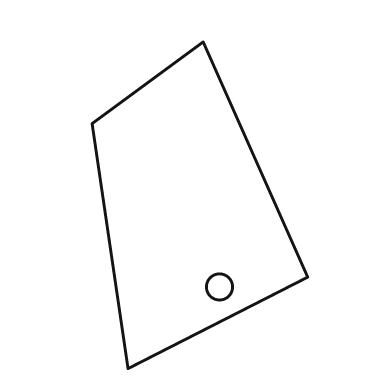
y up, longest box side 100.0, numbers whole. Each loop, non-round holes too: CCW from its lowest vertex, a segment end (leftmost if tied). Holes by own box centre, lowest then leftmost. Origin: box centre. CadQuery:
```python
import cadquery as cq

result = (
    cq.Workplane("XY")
    .moveTo(-22.0, -50.0)
    .lineTo(33.0, -22.0)
    .lineTo(1.0, 50.0)
    .lineTo(-33.0, 25.0)
    .close()
    .moveTo(6.0, -25.0)
    .circle(4.0)
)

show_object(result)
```